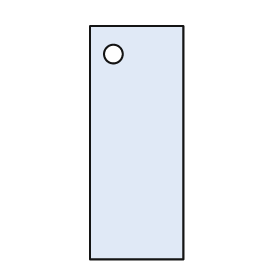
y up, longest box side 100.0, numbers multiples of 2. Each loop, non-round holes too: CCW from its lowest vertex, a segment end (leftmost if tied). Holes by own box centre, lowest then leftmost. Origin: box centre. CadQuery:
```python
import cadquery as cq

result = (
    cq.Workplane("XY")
    .moveTo(-20.0, -50.0)
    .lineTo(20.0, -50.0)
    .lineTo(20.0, 50.0)
    .lineTo(-20.0, 50.0)
    .close()
    .moveTo(-10.0, 38.0)
    .circle(4.0)
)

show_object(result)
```